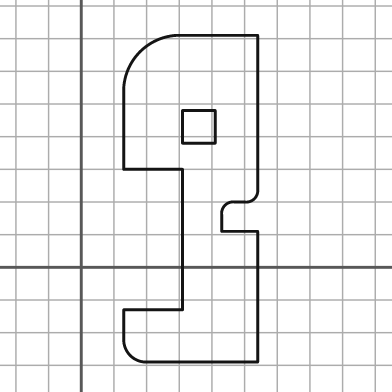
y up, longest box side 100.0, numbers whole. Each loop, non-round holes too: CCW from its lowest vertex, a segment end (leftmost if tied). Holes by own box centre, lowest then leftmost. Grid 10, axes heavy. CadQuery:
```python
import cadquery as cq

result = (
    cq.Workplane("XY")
    .moveTo(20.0, -29.0)
    .lineTo(54.0, -29.0)
    .lineTo(54.0, 11.0)
    .lineTo(43.0, 11.0)
    .lineTo(43.0, 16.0)
    .threePointArc((44.0, 19.0), (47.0, 20.0))
    .lineTo(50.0, 20.0)
    .threePointArc((53.0, 21.0), (54.0, 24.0))
    .lineTo(54.0, 71.0)
    .lineTo(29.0, 71.0)
    .threePointArc((18.0, 66.0), (13.0, 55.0))
    .lineTo(13.0, 30.0)
    .lineTo(31.0, 30.0)
    .lineTo(31.0, -13.0)
    .lineTo(13.0, -13.0)
    .lineTo(13.0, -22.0)
    .threePointArc((15.0, -27.0), (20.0, -29.0))
    .close()
    .moveTo(31.0, 38.0)
    .lineTo(41.0, 38.0)
    .lineTo(41.0, 48.0)
    .lineTo(31.0, 48.0)
    .close()
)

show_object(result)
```